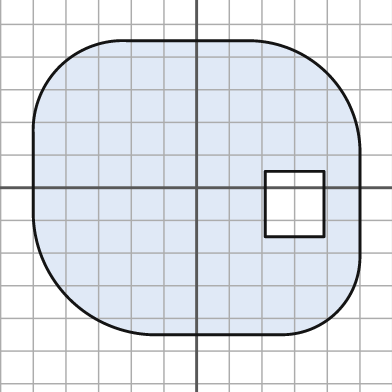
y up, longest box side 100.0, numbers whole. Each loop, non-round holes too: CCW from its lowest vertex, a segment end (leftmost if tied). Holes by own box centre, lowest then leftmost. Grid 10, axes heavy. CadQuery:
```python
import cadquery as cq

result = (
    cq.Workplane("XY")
    .moveTo(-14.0, -45.0)
    .lineTo(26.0, -45.0)
    .threePointArc((43.0, -38.0), (50.0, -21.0))
    .lineTo(50.0, 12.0)
    .threePointArc((40.0, 35.0), (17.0, 45.0))
    .lineTo(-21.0, 45.0)
    .threePointArc((-42.0, 37.0), (-50.0, 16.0))
    .lineTo(-50.0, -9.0)
    .threePointArc((-39.0, -34.0), (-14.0, -45.0))
    .close()
    .moveTo(21.0, -15.0)
    .lineTo(39.0, -15.0)
    .lineTo(39.0, 5.0)
    .lineTo(21.0, 5.0)
    .close()
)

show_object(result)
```